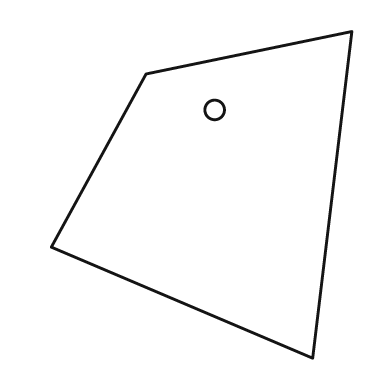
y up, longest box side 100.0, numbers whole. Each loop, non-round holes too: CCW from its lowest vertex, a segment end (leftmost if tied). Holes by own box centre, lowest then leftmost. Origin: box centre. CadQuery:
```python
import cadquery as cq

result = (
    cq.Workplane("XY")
    .moveTo(34.0, -50.0)
    .lineTo(46.0, 50.0)
    .lineTo(-17.0, 37.0)
    .lineTo(-46.0, -16.0)
    .close()
    .moveTo(4.0, 26.0)
    .circle(3.0)
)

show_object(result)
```